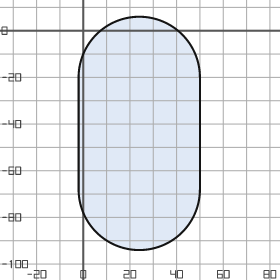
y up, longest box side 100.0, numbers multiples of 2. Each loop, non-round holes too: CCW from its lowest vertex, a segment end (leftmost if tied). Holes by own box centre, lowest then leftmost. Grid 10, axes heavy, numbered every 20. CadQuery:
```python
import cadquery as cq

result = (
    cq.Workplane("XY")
    .moveTo(-2.0, -68.0)
    .threePointArc((24.0, -94.0), (50.0, -68.0))
    .lineTo(50.0, -20.0)
    .threePointArc((24.0, 6.0), (-2.0, -20.0))
    .close()
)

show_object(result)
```